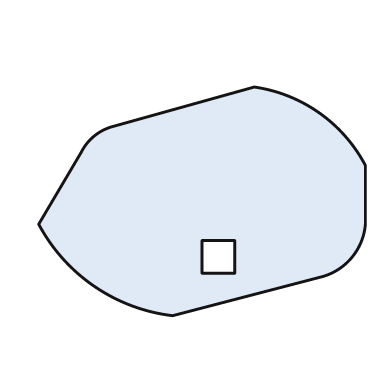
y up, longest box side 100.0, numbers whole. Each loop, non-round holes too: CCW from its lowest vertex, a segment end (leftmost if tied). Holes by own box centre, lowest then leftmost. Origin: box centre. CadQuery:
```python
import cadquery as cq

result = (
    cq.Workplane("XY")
    .moveTo(-9.0, -35.0)
    .lineTo(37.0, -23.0)
    .threePointArc((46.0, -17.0), (50.0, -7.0))
    .lineTo(50.0, 11.0)
    .threePointArc((36.0, 27.0), (16.0, 35.0))
    .lineTo(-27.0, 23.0)
    .threePointArc((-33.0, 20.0), (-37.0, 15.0))
    .lineTo(-50.0, -7.0)
    .threePointArc((-33.0, -26.0), (-9.0, -35.0))
    .close()
    .moveTo(0.0, -22.0)
    .lineTo(10.0, -22.0)
    .lineTo(10.0, -12.0)
    .lineTo(0.0, -12.0)
    .close()
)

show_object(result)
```